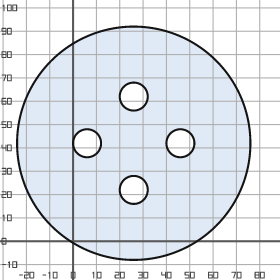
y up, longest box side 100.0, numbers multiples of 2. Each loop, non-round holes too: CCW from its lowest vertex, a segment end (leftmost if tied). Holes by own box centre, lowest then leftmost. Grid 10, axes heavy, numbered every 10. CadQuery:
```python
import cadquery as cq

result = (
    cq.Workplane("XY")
    .moveTo(26.0, 42.0)
    .circle(50.0)
    .moveTo(26.0, 22.0)
    .circle(6.0)
    .moveTo(6.0, 42.0)
    .circle(6.0)
    .moveTo(46.0, 42.0)
    .circle(6.0)
    .moveTo(26.0, 62.0)
    .circle(6.0)
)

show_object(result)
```